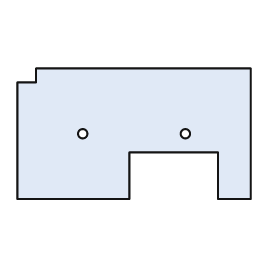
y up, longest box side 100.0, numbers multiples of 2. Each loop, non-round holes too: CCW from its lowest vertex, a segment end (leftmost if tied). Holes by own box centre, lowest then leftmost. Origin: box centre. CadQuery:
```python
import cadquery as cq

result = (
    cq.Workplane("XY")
    .moveTo(-50.0, -28.0)
    .lineTo(-2.0, -28.0)
    .lineTo(-2.0, -8.0)
    .lineTo(36.0, -8.0)
    .lineTo(36.0, -28.0)
    .lineTo(50.0, -28.0)
    .lineTo(50.0, 28.0)
    .lineTo(-42.0, 28.0)
    .lineTo(-42.0, 22.0)
    .lineTo(-50.0, 22.0)
    .close()
    .moveTo(-22.0, 0.0)
    .circle(2.0)
    .moveTo(22.0, 0.0)
    .circle(2.0)
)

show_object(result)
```